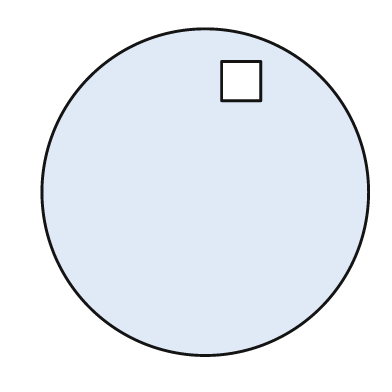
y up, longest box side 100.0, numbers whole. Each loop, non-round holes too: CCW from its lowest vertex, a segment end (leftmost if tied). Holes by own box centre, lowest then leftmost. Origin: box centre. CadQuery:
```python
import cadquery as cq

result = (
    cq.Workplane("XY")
    .moveTo(0.0, 0.0)
    .circle(50.0)
    .moveTo(5.0, 28.0)
    .lineTo(17.0, 28.0)
    .lineTo(17.0, 40.0)
    .lineTo(5.0, 40.0)
    .close()
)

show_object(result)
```